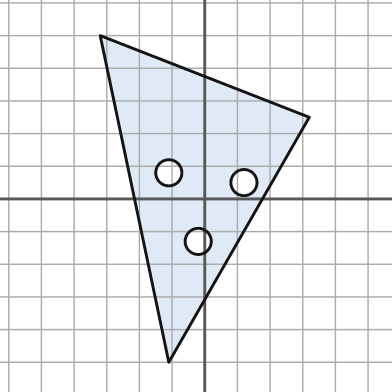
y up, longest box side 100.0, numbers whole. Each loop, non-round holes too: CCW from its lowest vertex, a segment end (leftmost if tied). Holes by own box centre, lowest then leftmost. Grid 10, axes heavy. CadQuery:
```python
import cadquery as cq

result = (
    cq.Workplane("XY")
    .moveTo(-11.0, -50.0)
    .lineTo(32.0, 25.0)
    .lineTo(-32.0, 50.0)
    .close()
    .moveTo(-2.0, -13.0)
    .circle(4.0)
    .moveTo(12.0, 5.0)
    .circle(4.0)
    .moveTo(-11.0, 8.0)
    .circle(4.0)
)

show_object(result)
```